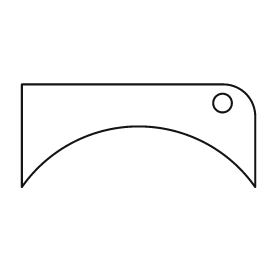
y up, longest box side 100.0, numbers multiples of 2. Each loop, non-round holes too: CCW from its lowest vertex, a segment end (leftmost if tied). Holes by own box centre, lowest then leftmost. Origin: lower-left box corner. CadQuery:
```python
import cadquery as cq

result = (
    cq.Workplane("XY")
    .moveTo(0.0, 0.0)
    .threePointArc((50.0, 26.0), (100.0, 0.0))
    .lineTo(100.0, 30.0)
    .threePointArc((96.0, 40.0), (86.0, 44.0))
    .lineTo(0.0, 44.0)
    .close()
    .moveTo(86.0, 36.0)
    .circle(4.0)
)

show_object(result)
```